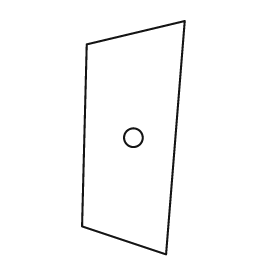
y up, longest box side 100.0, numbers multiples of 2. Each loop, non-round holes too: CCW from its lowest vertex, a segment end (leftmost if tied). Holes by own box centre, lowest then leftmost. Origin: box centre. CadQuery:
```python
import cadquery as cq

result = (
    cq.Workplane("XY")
    .moveTo(14.0, -50.0)
    .lineTo(22.0, 50.0)
    .lineTo(-20.0, 40.0)
    .lineTo(-22.0, -38.0)
    .close()
    .moveTo(0.0, 0.0)
    .circle(4.0)
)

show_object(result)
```